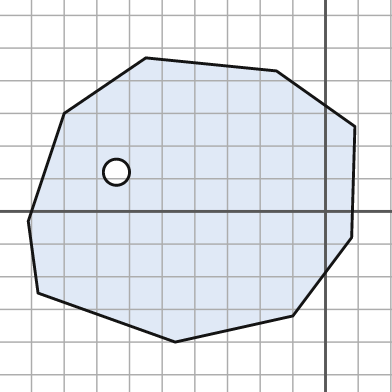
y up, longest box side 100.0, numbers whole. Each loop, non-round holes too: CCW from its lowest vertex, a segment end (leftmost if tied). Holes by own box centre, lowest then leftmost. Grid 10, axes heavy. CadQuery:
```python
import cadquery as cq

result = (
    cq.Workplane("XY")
    .moveTo(-46.0, -40.0)
    .lineTo(-10.0, -32.0)
    .lineTo(8.0, -8.0)
    .lineTo(9.0, 26.0)
    .lineTo(-15.0, 43.0)
    .lineTo(-55.0, 47.0)
    .lineTo(-80.0, 30.0)
    .lineTo(-91.0, -3.0)
    .lineTo(-88.0, -25.0)
    .close()
    .moveTo(-64.0, 12.0)
    .circle(4.0)
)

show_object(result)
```